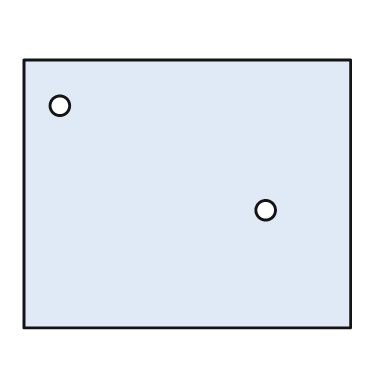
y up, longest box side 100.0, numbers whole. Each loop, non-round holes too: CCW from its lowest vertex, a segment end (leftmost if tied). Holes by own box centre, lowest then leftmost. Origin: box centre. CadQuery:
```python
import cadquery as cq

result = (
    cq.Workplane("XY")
    .moveTo(-50.0, -41.0)
    .lineTo(50.0, -41.0)
    .lineTo(50.0, 41.0)
    .lineTo(-50.0, 41.0)
    .close()
    .moveTo(24.0, -5.0)
    .circle(3.0)
    .moveTo(-39.0, 27.0)
    .circle(3.0)
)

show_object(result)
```